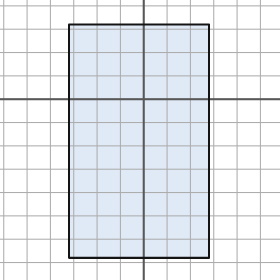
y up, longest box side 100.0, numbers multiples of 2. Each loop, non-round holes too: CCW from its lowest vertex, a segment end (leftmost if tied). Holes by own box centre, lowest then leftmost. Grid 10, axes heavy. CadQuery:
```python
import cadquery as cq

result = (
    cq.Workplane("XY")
    .moveTo(-32.0, -68.0)
    .lineTo(28.0, -68.0)
    .lineTo(28.0, 32.0)
    .lineTo(-32.0, 32.0)
    .close()
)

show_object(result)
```